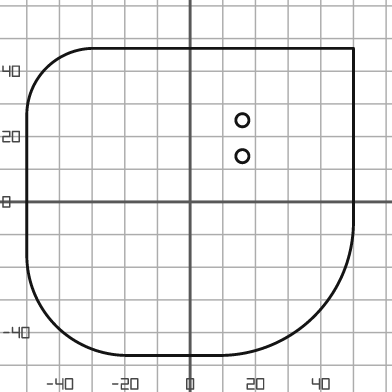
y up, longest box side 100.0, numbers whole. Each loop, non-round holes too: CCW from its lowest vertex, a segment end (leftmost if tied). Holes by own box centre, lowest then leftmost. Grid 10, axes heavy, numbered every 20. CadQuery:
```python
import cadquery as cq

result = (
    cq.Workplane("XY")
    .moveTo(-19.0, -47.0)
    .lineTo(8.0, -47.0)
    .threePointArc((38.0, -35.0), (50.0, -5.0))
    .lineTo(50.0, 47.0)
    .lineTo(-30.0, 47.0)
    .threePointArc((-44.0, 41.0), (-50.0, 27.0))
    .lineTo(-50.0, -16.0)
    .threePointArc((-41.0, -38.0), (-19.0, -47.0))
    .close()
    .moveTo(16.0, 14.0)
    .circle(2.0)
    .moveTo(16.0, 25.0)
    .circle(2.0)
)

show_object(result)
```